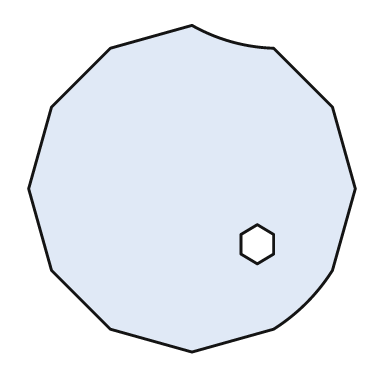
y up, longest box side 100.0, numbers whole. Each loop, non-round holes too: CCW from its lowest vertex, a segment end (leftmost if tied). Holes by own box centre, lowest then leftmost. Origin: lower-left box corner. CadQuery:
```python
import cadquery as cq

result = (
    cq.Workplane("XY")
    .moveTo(50.0, 0.0)
    .lineTo(75.0, 7.0)
    .threePointArc((85.0, 15.0), (93.0, 25.0))
    .lineTo(100.0, 50.0)
    .lineTo(93.0, 75.0)
    .lineTo(75.0, 93.0)
    .threePointArc((62.0, 95.0), (50.0, 100.0))
    .lineTo(25.0, 93.0)
    .lineTo(7.0, 75.0)
    .lineTo(0.0, 50.0)
    .lineTo(7.0, 25.0)
    .lineTo(25.0, 7.0)
    .close()
    .moveTo(70.0, 27.0)
    .lineTo(75.0, 30.0)
    .lineTo(75.0, 36.0)
    .lineTo(70.0, 39.0)
    .lineTo(65.0, 36.0)
    .lineTo(65.0, 30.0)
    .close()
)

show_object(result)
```